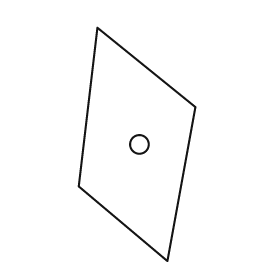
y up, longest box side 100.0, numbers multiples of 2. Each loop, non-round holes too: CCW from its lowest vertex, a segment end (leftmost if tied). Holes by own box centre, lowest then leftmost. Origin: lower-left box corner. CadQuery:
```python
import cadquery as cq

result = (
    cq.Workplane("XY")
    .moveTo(38.0, 0.0)
    .lineTo(50.0, 66.0)
    .lineTo(8.0, 100.0)
    .lineTo(0.0, 32.0)
    .close()
    .moveTo(26.0, 50.0)
    .circle(4.0)
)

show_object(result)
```